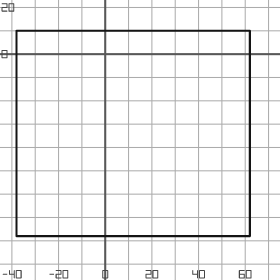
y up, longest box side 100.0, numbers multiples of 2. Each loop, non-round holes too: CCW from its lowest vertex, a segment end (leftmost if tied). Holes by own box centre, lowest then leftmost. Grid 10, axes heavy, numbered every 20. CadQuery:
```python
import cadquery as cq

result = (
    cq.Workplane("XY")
    .moveTo(-38.0, -78.0)
    .lineTo(62.0, -78.0)
    .lineTo(62.0, 10.0)
    .lineTo(-38.0, 10.0)
    .close()
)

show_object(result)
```